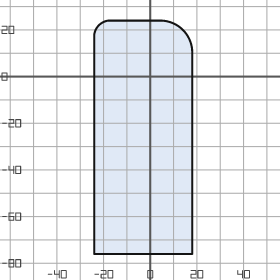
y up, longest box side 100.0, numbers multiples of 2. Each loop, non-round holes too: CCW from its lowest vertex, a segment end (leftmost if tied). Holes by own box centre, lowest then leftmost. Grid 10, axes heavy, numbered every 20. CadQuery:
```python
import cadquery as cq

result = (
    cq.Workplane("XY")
    .moveTo(-24.0, -76.0)
    .lineTo(18.0, -76.0)
    .lineTo(18.0, 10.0)
    .threePointArc((14.0, 20.0), (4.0, 24.0))
    .lineTo(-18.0, 24.0)
    .threePointArc((-22.0, 22.0), (-24.0, 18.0))
    .close()
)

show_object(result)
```